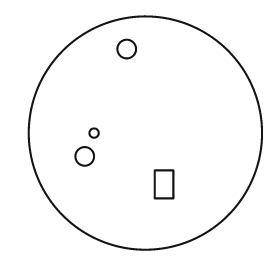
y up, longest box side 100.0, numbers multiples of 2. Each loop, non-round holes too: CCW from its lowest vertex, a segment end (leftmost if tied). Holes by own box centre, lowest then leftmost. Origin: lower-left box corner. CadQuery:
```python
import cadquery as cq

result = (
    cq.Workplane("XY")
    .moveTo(50.0, 50.0)
    .circle(50.0)
    .moveTo(54.0, 22.0)
    .lineTo(62.0, 22.0)
    .lineTo(62.0, 34.0)
    .lineTo(54.0, 34.0)
    .close()
    .moveTo(24.0, 40.0)
    .circle(4.0)
    .moveTo(28.0, 50.0)
    .circle(2.0)
    .moveTo(42.0, 86.0)
    .circle(4.0)
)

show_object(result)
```